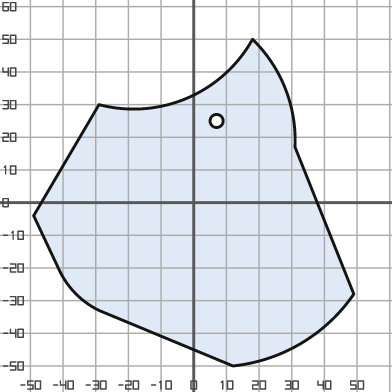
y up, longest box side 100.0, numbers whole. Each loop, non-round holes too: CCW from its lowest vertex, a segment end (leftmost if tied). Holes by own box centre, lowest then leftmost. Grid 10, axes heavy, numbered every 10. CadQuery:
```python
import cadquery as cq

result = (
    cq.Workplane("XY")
    .moveTo(12.0, -50.0)
    .threePointArc((33.0, -43.0), (49.0, -28.0))
    .lineTo(31.0, 17.0)
    .threePointArc((28.0, 35.0), (18.0, 50.0))
    .threePointArc((-2.0, 32.0), (-29.0, 30.0))
    .lineTo(-49.0, -4.0)
    .lineTo(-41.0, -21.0)
    .threePointArc((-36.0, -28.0), (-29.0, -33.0))
    .close()
    .moveTo(7.0, 25.0)
    .circle(2.0)
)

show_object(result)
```